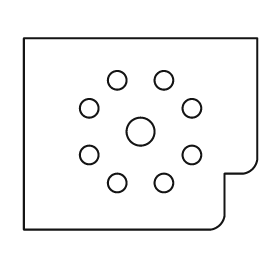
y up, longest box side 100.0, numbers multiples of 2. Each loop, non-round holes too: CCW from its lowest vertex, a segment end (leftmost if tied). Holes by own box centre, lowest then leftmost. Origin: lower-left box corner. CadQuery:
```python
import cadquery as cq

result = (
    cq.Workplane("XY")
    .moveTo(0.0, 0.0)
    .lineTo(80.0, 0.0)
    .threePointArc((84.0, 2.0), (86.0, 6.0))
    .lineTo(86.0, 24.0)
    .lineTo(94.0, 24.0)
    .threePointArc((98.0, 26.0), (100.0, 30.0))
    .lineTo(100.0, 82.0)
    .lineTo(0.0, 82.0)
    .close()
    .moveTo(40.0, 20.0)
    .circle(4.0)
    .moveTo(60.0, 20.0)
    .circle(4.0)
    .moveTo(28.0, 32.0)
    .circle(4.0)
    .moveTo(72.0, 32.0)
    .circle(4.0)
    .moveTo(50.0, 42.0)
    .circle(6.0)
    .moveTo(28.0, 52.0)
    .circle(4.0)
    .moveTo(72.0, 52.0)
    .circle(4.0)
    .moveTo(40.0, 64.0)
    .circle(4.0)
    .moveTo(60.0, 64.0)
    .circle(4.0)
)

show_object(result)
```